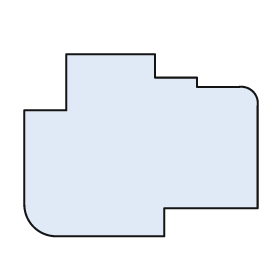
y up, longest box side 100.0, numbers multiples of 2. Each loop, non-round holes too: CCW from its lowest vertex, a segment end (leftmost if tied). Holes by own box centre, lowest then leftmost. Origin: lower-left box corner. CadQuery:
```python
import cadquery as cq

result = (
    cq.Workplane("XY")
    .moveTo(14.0, 0.0)
    .lineTo(60.0, 0.0)
    .lineTo(60.0, 12.0)
    .lineTo(100.0, 12.0)
    .lineTo(100.0, 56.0)
    .threePointArc((98.0, 62.0), (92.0, 64.0))
    .lineTo(74.0, 64.0)
    .lineTo(74.0, 68.0)
    .lineTo(56.0, 68.0)
    .lineTo(56.0, 78.0)
    .lineTo(18.0, 78.0)
    .lineTo(18.0, 54.0)
    .lineTo(0.0, 54.0)
    .lineTo(0.0, 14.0)
    .threePointArc((4.0, 4.0), (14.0, 0.0))
    .close()
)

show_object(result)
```